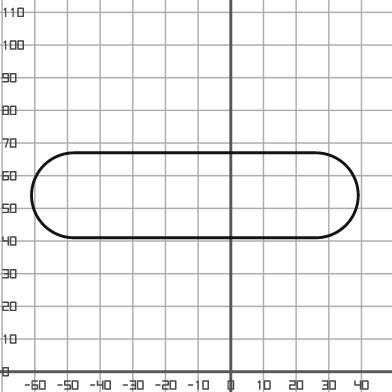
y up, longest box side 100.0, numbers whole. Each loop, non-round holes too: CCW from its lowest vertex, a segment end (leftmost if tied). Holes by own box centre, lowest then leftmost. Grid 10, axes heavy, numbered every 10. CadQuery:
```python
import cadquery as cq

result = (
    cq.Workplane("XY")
    .moveTo(-48.0, 41.0)
    .lineTo(26.0, 41.0)
    .threePointArc((39.0, 54.0), (26.0, 67.0))
    .lineTo(-48.0, 67.0)
    .threePointArc((-61.0, 54.0), (-48.0, 41.0))
    .close()
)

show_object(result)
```